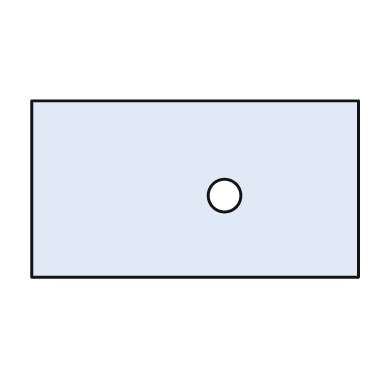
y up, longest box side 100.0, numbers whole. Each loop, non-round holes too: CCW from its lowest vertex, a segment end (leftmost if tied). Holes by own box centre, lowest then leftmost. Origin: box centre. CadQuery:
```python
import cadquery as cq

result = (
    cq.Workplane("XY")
    .moveTo(-50.0, -27.0)
    .lineTo(50.0, -27.0)
    .lineTo(50.0, 27.0)
    .lineTo(-50.0, 27.0)
    .close()
    .moveTo(9.0, -2.0)
    .circle(5.0)
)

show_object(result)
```